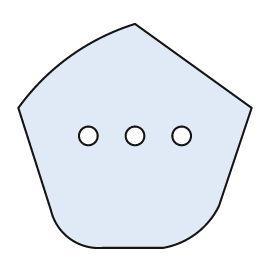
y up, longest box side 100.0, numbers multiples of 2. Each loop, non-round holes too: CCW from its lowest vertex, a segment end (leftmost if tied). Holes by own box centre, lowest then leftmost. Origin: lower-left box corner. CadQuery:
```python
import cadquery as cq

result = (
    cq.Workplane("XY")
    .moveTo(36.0, 0.0)
    .lineTo(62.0, 0.0)
    .threePointArc((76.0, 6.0), (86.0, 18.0))
    .lineTo(100.0, 60.0)
    .lineTo(50.0, 96.0)
    .threePointArc((22.0, 82.0), (0.0, 60.0))
    .lineTo(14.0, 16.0)
    .threePointArc((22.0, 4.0), (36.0, 0.0))
    .close()
    .moveTo(30.0, 48.0)
    .circle(4.0)
    .moveTo(50.0, 48.0)
    .circle(4.0)
    .moveTo(70.0, 48.0)
    .circle(4.0)
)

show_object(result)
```